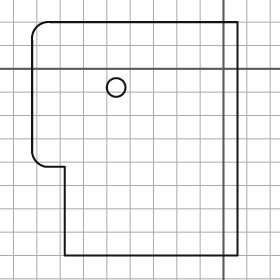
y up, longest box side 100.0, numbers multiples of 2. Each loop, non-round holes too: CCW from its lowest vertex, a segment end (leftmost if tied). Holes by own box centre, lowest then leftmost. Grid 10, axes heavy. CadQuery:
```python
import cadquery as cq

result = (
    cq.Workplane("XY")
    .moveTo(-68.0, -80.0)
    .lineTo(6.0, -80.0)
    .lineTo(6.0, 20.0)
    .lineTo(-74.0, 20.0)
    .threePointArc((-80.0, 18.0), (-82.0, 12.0))
    .lineTo(-82.0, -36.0)
    .threePointArc((-80.0, -40.0), (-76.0, -42.0))
    .lineTo(-68.0, -42.0)
    .close()
    .moveTo(-46.0, -8.0)
    .circle(4.0)
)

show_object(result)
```